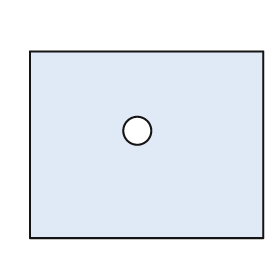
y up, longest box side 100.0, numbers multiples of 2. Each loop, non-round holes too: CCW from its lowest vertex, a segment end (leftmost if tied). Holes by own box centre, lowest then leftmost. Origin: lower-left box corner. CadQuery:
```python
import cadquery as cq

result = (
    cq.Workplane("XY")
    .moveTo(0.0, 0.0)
    .lineTo(100.0, 0.0)
    .lineTo(100.0, 80.0)
    .lineTo(0.0, 80.0)
    .close()
    .moveTo(46.0, 46.0)
    .circle(6.0)
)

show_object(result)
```